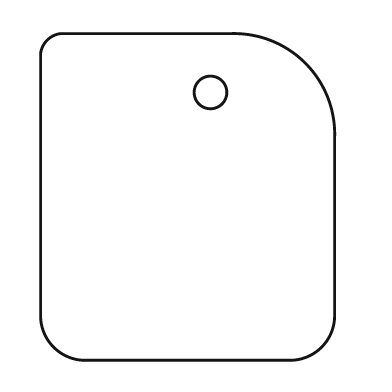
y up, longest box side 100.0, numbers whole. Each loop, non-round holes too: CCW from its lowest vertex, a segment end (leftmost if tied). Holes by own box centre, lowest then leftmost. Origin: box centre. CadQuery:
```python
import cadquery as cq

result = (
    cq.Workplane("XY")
    .moveTo(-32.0, -50.0)
    .lineTo(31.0, -50.0)
    .threePointArc((41.0, -46.0), (45.0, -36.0))
    .lineTo(45.0, 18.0)
    .threePointArc((36.0, 41.0), (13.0, 50.0))
    .lineTo(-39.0, 50.0)
    .threePointArc((-43.0, 48.0), (-45.0, 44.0))
    .lineTo(-45.0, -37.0)
    .threePointArc((-41.0, -46.0), (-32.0, -50.0))
    .close()
    .moveTo(7.0, 32.0)
    .circle(5.0)
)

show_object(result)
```